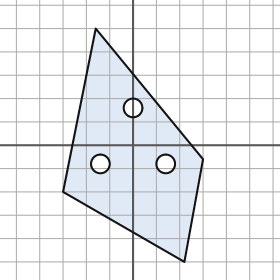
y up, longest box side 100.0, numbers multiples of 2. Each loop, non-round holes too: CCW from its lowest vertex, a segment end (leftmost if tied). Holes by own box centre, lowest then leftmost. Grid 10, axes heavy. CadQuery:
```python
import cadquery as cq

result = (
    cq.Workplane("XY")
    .moveTo(22.0, -50.0)
    .lineTo(30.0, -6.0)
    .lineTo(-16.0, 50.0)
    .lineTo(-30.0, -20.0)
    .close()
    .moveTo(-14.0, -8.0)
    .circle(4.0)
    .moveTo(14.0, -8.0)
    .circle(4.0)
    .moveTo(0.0, 16.0)
    .circle(4.0)
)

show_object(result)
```